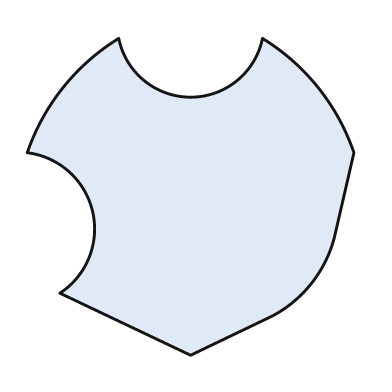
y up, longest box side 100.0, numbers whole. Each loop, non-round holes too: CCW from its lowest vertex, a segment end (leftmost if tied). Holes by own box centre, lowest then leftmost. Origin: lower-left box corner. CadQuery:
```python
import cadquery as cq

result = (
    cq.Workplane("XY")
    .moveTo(50.0, 0.0)
    .lineTo(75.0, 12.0)
    .threePointArc((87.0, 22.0), (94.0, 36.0))
    .lineTo(100.0, 62.0)
    .threePointArc((89.0, 82.0), (72.0, 97.0))
    .threePointArc((50.0, 79.0), (28.0, 97.0))
    .threePointArc((11.0, 82.0), (0.0, 62.0))
    .threePointArc((20.0, 44.0), (10.0, 19.0))
    .close()
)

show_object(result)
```